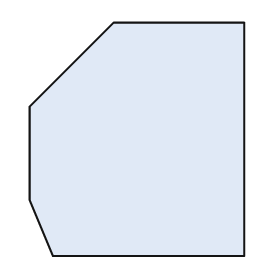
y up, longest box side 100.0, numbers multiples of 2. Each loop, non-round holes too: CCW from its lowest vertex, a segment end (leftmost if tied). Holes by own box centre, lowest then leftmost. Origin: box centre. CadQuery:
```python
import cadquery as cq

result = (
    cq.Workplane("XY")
    .moveTo(-36.0, -50.0)
    .lineTo(46.0, -50.0)
    .lineTo(46.0, 50.0)
    .lineTo(-10.0, 50.0)
    .lineTo(-46.0, 14.0)
    .lineTo(-46.0, -26.0)
    .close()
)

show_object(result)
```